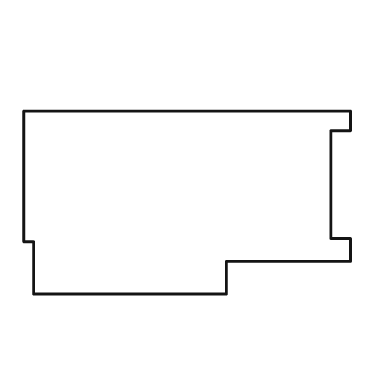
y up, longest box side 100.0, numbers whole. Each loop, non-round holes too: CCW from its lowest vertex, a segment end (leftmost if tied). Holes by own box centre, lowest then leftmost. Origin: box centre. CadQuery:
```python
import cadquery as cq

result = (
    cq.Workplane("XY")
    .moveTo(-47.0, -28.0)
    .lineTo(12.0, -28.0)
    .lineTo(12.0, -18.0)
    .lineTo(50.0, -18.0)
    .lineTo(50.0, -11.0)
    .lineTo(44.0, -11.0)
    .lineTo(44.0, 22.0)
    .lineTo(50.0, 22.0)
    .lineTo(50.0, 28.0)
    .lineTo(-50.0, 28.0)
    .lineTo(-50.0, -12.0)
    .lineTo(-47.0, -12.0)
    .close()
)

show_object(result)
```